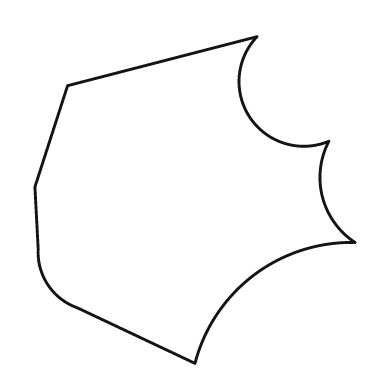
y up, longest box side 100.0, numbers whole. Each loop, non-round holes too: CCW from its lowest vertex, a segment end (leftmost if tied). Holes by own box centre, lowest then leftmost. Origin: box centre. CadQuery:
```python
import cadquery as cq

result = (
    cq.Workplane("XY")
    .moveTo(0.0, -50.0)
    .threePointArc((18.0, -23.0), (49.0, -13.0))
    .threePointArc((39.0, 1.0), (41.0, 18.0))
    .threePointArc((17.0, 25.0), (19.0, 50.0))
    .lineTo(-39.0, 35.0)
    .lineTo(-49.0, 4.0)
    .lineTo(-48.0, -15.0)
    .threePointArc((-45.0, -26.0), (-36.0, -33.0))
    .close()
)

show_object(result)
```